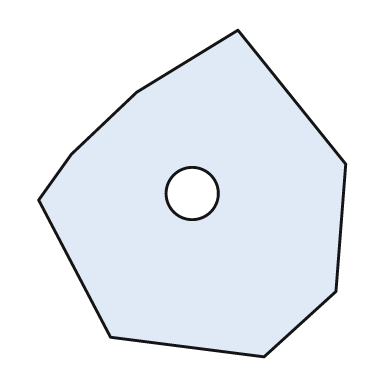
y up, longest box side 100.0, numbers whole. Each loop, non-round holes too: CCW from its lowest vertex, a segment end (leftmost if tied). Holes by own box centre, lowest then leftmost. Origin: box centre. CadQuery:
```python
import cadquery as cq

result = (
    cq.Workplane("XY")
    .moveTo(22.0, -50.0)
    .lineTo(44.0, -30.0)
    .lineTo(47.0, 9.0)
    .lineTo(14.0, 50.0)
    .lineTo(-17.0, 31.0)
    .lineTo(-37.0, 12.0)
    .lineTo(-47.0, -2.0)
    .lineTo(-25.0, -44.0)
    .close()
    .moveTo(0.0, 0.0)
    .circle(8.0)
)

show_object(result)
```